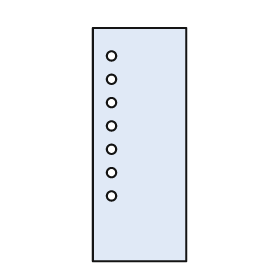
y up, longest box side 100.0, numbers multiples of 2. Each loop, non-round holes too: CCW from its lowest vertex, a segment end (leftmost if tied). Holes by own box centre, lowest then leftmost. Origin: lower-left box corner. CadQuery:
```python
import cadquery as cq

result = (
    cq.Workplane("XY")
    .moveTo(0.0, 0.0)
    .lineTo(40.0, 0.0)
    .lineTo(40.0, 100.0)
    .lineTo(0.0, 100.0)
    .close()
    .moveTo(8.0, 28.0)
    .circle(2.0)
    .moveTo(8.0, 38.0)
    .circle(2.0)
    .moveTo(8.0, 48.0)
    .circle(2.0)
    .moveTo(8.0, 58.0)
    .circle(2.0)
    .moveTo(8.0, 68.0)
    .circle(2.0)
    .moveTo(8.0, 78.0)
    .circle(2.0)
    .moveTo(8.0, 88.0)
    .circle(2.0)
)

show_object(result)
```